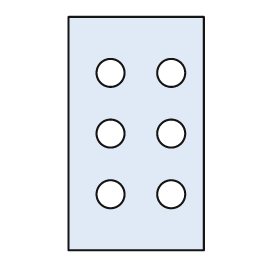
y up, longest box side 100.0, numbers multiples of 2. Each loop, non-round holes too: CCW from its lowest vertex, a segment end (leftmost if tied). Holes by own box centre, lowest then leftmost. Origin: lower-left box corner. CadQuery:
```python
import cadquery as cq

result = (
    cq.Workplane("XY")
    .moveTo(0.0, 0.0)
    .lineTo(58.0, 0.0)
    .lineTo(58.0, 100.0)
    .lineTo(0.0, 100.0)
    .close()
    .moveTo(18.0, 24.0)
    .circle(6.0)
    .moveTo(44.0, 24.0)
    .circle(6.0)
    .moveTo(18.0, 50.0)
    .circle(6.0)
    .moveTo(44.0, 50.0)
    .circle(6.0)
    .moveTo(18.0, 76.0)
    .circle(6.0)
    .moveTo(44.0, 76.0)
    .circle(6.0)
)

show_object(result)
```